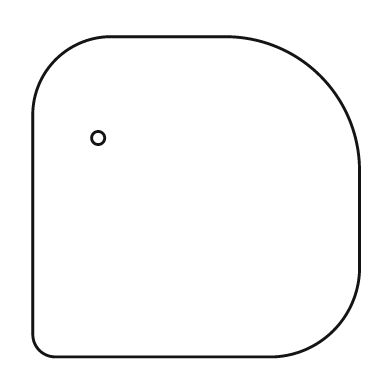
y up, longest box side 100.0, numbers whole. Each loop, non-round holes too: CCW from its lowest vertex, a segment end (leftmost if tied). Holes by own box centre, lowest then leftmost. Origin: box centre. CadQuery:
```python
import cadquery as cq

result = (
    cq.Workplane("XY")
    .moveTo(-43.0, -49.0)
    .lineTo(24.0, -49.0)
    .threePointArc((42.0, -41.0), (50.0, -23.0))
    .lineTo(50.0, 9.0)
    .threePointArc((38.0, 37.0), (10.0, 49.0))
    .lineTo(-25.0, 49.0)
    .threePointArc((-43.0, 42.0), (-50.0, 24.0))
    .lineTo(-50.0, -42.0)
    .threePointArc((-48.0, -47.0), (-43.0, -49.0))
    .close()
    .moveTo(-30.0, 18.0)
    .circle(2.0)
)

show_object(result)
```